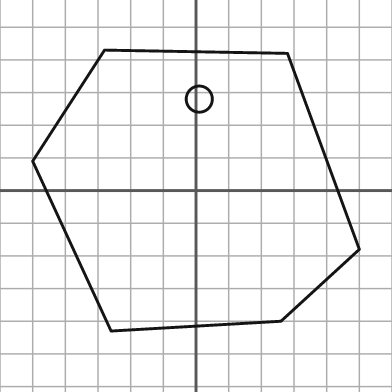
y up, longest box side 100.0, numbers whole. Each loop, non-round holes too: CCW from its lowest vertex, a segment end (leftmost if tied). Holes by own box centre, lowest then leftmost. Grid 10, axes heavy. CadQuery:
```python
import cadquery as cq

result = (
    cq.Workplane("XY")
    .moveTo(-26.0, -43.0)
    .lineTo(26.0, -40.0)
    .lineTo(50.0, -18.0)
    .lineTo(28.0, 42.0)
    .lineTo(-28.0, 43.0)
    .lineTo(-50.0, 9.0)
    .close()
    .moveTo(1.0, 28.0)
    .circle(4.0)
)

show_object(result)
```